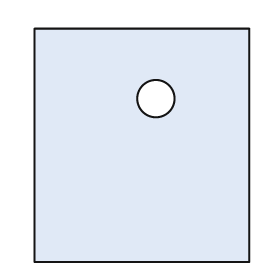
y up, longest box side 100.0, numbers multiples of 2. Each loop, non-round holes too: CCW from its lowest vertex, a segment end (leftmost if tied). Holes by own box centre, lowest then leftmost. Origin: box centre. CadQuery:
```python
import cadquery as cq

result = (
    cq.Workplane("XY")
    .moveTo(-46.0, -50.0)
    .lineTo(46.0, -50.0)
    .lineTo(46.0, 50.0)
    .lineTo(-46.0, 50.0)
    .close()
    .moveTo(6.0, 20.0)
    .circle(8.0)
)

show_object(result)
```